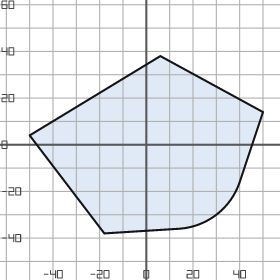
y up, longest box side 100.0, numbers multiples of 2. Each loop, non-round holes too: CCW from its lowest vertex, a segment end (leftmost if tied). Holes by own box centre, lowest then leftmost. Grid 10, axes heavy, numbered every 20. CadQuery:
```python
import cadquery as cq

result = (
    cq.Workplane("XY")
    .moveTo(-18.0, -38.0)
    .lineTo(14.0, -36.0)
    .threePointArc((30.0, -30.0), (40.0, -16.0))
    .lineTo(50.0, 14.0)
    .lineTo(6.0, 38.0)
    .lineTo(-50.0, 4.0)
    .close()
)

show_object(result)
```